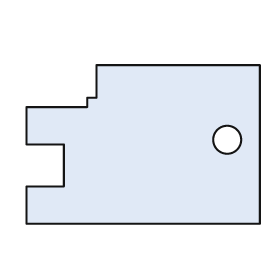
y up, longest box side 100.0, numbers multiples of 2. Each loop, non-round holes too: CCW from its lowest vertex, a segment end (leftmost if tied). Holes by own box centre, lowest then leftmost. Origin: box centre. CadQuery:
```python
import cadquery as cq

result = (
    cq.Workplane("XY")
    .moveTo(-50.0, -34.0)
    .lineTo(50.0, -34.0)
    .lineTo(50.0, 34.0)
    .lineTo(-20.0, 34.0)
    .lineTo(-20.0, 20.0)
    .lineTo(-24.0, 20.0)
    .lineTo(-24.0, 16.0)
    .lineTo(-50.0, 16.0)
    .lineTo(-50.0, 0.0)
    .lineTo(-34.0, 0.0)
    .lineTo(-34.0, -18.0)
    .lineTo(-50.0, -18.0)
    .close()
    .moveTo(36.0, 2.0)
    .circle(6.0)
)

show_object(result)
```